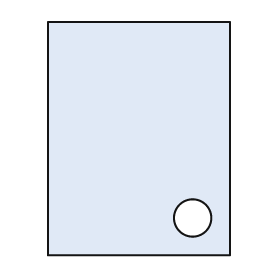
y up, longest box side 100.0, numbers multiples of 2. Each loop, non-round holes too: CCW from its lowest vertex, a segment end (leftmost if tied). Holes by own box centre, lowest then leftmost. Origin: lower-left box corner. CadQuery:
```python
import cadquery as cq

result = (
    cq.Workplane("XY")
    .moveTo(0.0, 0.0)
    .lineTo(78.0, 0.0)
    .lineTo(78.0, 100.0)
    .lineTo(0.0, 100.0)
    .close()
    .moveTo(62.0, 16.0)
    .circle(8.0)
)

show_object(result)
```